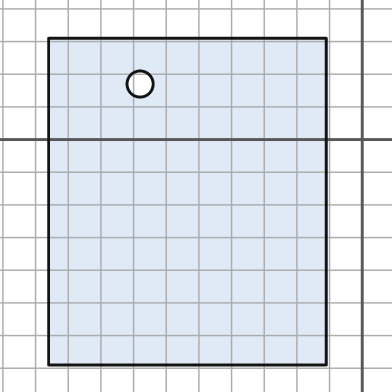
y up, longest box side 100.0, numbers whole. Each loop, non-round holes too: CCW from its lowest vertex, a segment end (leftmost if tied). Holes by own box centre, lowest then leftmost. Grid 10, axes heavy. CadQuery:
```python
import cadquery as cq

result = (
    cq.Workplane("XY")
    .moveTo(-96.0, -69.0)
    .lineTo(-11.0, -69.0)
    .lineTo(-11.0, 31.0)
    .lineTo(-96.0, 31.0)
    .close()
    .moveTo(-68.0, 17.0)
    .circle(4.0)
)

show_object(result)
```